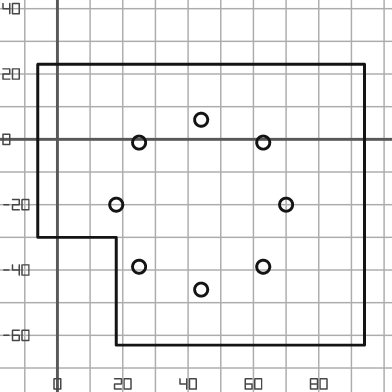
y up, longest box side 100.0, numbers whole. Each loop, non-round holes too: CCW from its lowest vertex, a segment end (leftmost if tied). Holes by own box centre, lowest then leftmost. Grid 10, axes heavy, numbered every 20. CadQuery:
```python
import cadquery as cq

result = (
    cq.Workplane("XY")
    .moveTo(18.0, -63.0)
    .lineTo(94.0, -63.0)
    .lineTo(94.0, 23.0)
    .lineTo(-6.0, 23.0)
    .lineTo(-6.0, -30.0)
    .lineTo(18.0, -30.0)
    .close()
    .moveTo(44.0, -46.0)
    .circle(2.0)
    .moveTo(25.0, -39.0)
    .circle(2.0)
    .moveTo(63.0, -39.0)
    .circle(2.0)
    .moveTo(18.0, -20.0)
    .circle(2.0)
    .moveTo(70.0, -20.0)
    .circle(2.0)
    .moveTo(25.0, -1.0)
    .circle(2.0)
    .moveTo(63.0, -1.0)
    .circle(2.0)
    .moveTo(44.0, 6.0)
    .circle(2.0)
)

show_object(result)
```